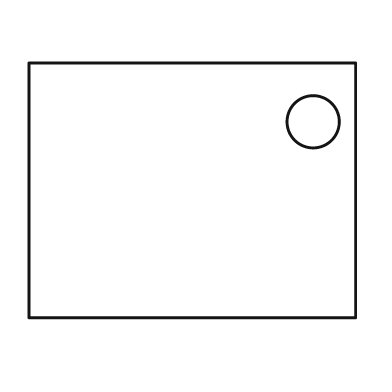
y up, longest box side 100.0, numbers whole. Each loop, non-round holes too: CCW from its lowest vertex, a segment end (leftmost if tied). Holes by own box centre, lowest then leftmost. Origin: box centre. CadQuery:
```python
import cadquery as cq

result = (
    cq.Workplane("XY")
    .moveTo(-50.0, -39.0)
    .lineTo(50.0, -39.0)
    .lineTo(50.0, 39.0)
    .lineTo(-50.0, 39.0)
    .close()
    .moveTo(37.0, 21.0)
    .circle(8.0)
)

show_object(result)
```